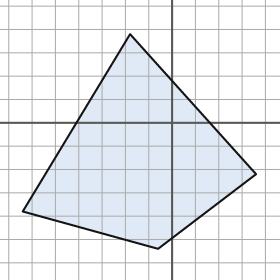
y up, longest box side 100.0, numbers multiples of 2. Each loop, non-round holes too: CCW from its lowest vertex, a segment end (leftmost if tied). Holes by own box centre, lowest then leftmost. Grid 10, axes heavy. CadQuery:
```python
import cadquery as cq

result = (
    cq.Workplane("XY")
    .moveTo(-6.0, -54.0)
    .lineTo(36.0, -22.0)
    .lineTo(-18.0, 38.0)
    .lineTo(-64.0, -38.0)
    .close()
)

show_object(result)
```